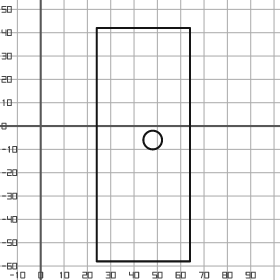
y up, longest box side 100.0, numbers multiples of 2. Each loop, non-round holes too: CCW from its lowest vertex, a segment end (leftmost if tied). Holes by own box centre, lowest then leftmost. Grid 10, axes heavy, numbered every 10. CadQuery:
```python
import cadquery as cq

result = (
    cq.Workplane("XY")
    .moveTo(24.0, -58.0)
    .lineTo(64.0, -58.0)
    .lineTo(64.0, 42.0)
    .lineTo(24.0, 42.0)
    .close()
    .moveTo(48.0, -6.0)
    .circle(4.0)
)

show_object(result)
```